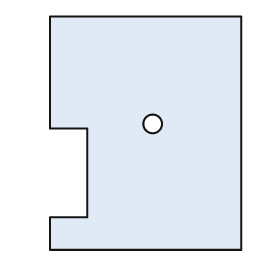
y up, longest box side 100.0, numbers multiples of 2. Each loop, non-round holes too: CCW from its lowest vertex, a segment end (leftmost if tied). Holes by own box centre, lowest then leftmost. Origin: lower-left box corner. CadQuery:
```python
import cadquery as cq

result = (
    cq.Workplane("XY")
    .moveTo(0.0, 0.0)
    .lineTo(82.0, 0.0)
    .lineTo(82.0, 100.0)
    .lineTo(0.0, 100.0)
    .lineTo(0.0, 52.0)
    .lineTo(16.0, 52.0)
    .lineTo(16.0, 14.0)
    .lineTo(0.0, 14.0)
    .close()
    .moveTo(44.0, 54.0)
    .circle(4.0)
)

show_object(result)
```